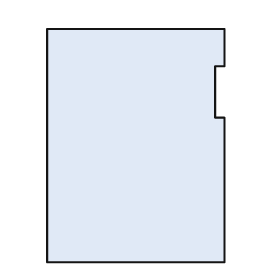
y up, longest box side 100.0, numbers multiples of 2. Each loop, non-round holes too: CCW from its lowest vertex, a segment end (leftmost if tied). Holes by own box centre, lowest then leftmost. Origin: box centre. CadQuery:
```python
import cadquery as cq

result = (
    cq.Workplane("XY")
    .moveTo(-38.0, -50.0)
    .lineTo(38.0, -50.0)
    .lineTo(38.0, 12.0)
    .lineTo(34.0, 12.0)
    .lineTo(34.0, 34.0)
    .lineTo(38.0, 34.0)
    .lineTo(38.0, 50.0)
    .lineTo(-38.0, 50.0)
    .close()
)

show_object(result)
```